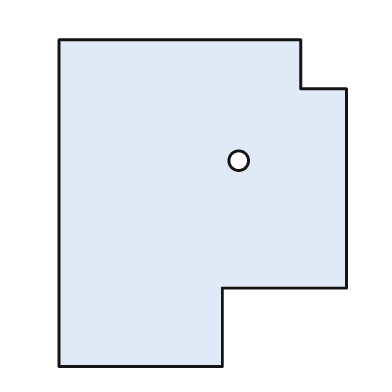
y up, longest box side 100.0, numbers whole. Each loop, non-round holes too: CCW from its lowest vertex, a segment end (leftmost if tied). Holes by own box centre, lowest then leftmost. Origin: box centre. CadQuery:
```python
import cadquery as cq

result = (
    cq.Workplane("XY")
    .moveTo(-44.0, -50.0)
    .lineTo(6.0, -50.0)
    .lineTo(6.0, -26.0)
    .lineTo(44.0, -26.0)
    .lineTo(44.0, 35.0)
    .lineTo(30.0, 35.0)
    .lineTo(30.0, 50.0)
    .lineTo(-44.0, 50.0)
    .close()
    .moveTo(11.0, 13.0)
    .circle(3.0)
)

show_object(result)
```